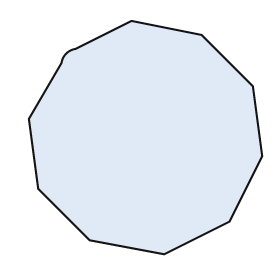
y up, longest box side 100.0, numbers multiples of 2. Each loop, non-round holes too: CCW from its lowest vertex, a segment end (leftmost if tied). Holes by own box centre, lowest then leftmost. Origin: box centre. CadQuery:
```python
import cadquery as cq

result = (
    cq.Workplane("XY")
    .moveTo(8.0, -50.0)
    .lineTo(36.0, -36.0)
    .lineTo(50.0, -8.0)
    .lineTo(46.0, 22.0)
    .lineTo(24.0, 44.0)
    .lineTo(-6.0, 50.0)
    .lineTo(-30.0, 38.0)
    .threePointArc((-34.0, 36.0), (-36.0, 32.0))
    .lineTo(-50.0, 8.0)
    .lineTo(-46.0, -22.0)
    .lineTo(-24.0, -44.0)
    .close()
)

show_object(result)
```